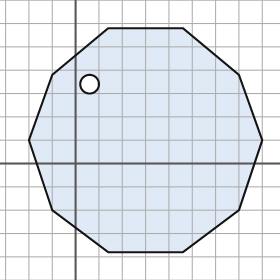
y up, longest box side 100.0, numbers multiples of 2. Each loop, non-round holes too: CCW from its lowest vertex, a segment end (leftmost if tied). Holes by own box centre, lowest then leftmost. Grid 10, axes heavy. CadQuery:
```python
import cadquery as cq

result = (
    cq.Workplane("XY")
    .moveTo(14.0, -38.0)
    .lineTo(46.0, -38.0)
    .lineTo(70.0, -20.0)
    .lineTo(80.0, 10.0)
    .lineTo(70.0, 38.0)
    .lineTo(46.0, 58.0)
    .lineTo(14.0, 58.0)
    .lineTo(-10.0, 38.0)
    .lineTo(-20.0, 10.0)
    .lineTo(-10.0, -20.0)
    .close()
    .moveTo(6.0, 34.0)
    .circle(4.0)
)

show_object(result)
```